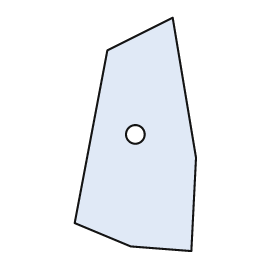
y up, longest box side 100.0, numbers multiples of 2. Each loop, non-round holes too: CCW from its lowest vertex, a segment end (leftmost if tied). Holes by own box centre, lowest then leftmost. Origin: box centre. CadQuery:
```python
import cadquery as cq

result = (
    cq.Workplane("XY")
    .moveTo(24.0, -50.0)
    .lineTo(26.0, -10.0)
    .lineTo(16.0, 50.0)
    .lineTo(-12.0, 36.0)
    .lineTo(-26.0, -38.0)
    .lineTo(-2.0, -48.0)
    .close()
    .moveTo(0.0, 0.0)
    .circle(4.0)
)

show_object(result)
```